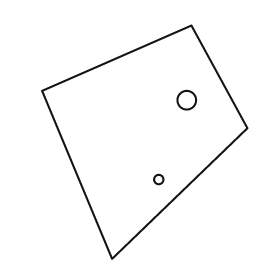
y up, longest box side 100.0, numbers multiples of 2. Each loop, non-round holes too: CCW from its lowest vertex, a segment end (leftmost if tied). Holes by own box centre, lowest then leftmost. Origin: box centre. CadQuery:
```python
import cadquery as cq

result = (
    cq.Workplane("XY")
    .moveTo(-14.0, -50.0)
    .lineTo(44.0, 6.0)
    .lineTo(20.0, 50.0)
    .lineTo(-44.0, 22.0)
    .close()
    .moveTo(6.0, -16.0)
    .circle(2.0)
    .moveTo(18.0, 18.0)
    .circle(4.0)
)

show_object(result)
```